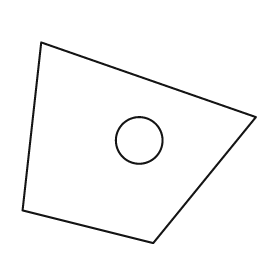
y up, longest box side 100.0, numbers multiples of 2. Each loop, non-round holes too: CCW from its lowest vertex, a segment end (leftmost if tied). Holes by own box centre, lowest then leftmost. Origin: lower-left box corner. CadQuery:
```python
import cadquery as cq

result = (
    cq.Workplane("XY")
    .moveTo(56.0, 0.0)
    .lineTo(100.0, 54.0)
    .lineTo(8.0, 86.0)
    .lineTo(0.0, 14.0)
    .close()
    .moveTo(50.0, 44.0)
    .circle(10.0)
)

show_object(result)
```